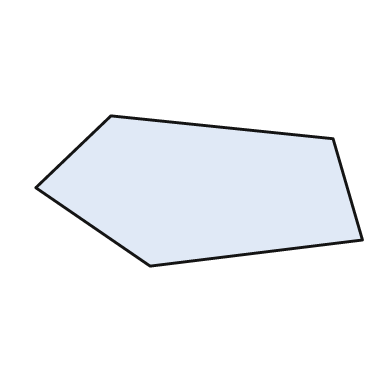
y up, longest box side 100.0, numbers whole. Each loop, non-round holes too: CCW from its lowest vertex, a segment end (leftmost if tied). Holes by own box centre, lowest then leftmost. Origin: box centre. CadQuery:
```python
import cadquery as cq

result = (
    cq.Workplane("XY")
    .moveTo(-15.0, -23.0)
    .lineTo(50.0, -15.0)
    .lineTo(41.0, 16.0)
    .lineTo(-27.0, 23.0)
    .lineTo(-50.0, 1.0)
    .close()
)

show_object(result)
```